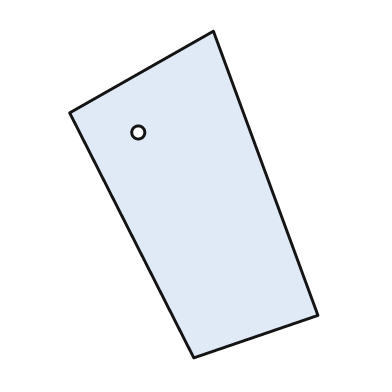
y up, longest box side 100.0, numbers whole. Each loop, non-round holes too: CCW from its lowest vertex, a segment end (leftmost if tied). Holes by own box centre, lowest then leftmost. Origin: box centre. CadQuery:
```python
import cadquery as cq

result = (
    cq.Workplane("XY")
    .moveTo(0.0, -50.0)
    .lineTo(38.0, -37.0)
    .lineTo(6.0, 50.0)
    .lineTo(-38.0, 25.0)
    .close()
    .moveTo(-17.0, 19.0)
    .circle(2.0)
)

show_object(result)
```